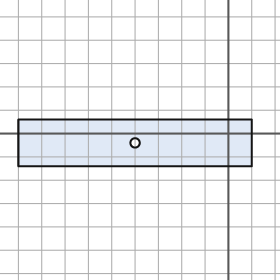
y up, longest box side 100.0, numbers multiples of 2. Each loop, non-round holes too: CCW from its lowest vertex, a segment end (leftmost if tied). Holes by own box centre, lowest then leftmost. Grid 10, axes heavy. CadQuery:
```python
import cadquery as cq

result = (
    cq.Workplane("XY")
    .moveTo(-90.0, -14.0)
    .lineTo(10.0, -14.0)
    .lineTo(10.0, 6.0)
    .lineTo(-90.0, 6.0)
    .close()
    .moveTo(-40.0, -4.0)
    .circle(2.0)
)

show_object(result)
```